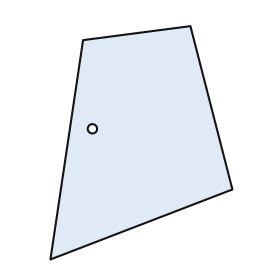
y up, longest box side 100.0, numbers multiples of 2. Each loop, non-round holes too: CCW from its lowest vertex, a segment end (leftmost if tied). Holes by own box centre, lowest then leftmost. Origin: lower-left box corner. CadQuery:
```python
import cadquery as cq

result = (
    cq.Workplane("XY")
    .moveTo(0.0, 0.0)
    .lineTo(78.0, 30.0)
    .lineTo(60.0, 100.0)
    .lineTo(14.0, 94.0)
    .close()
    .moveTo(18.0, 56.0)
    .circle(2.0)
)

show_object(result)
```